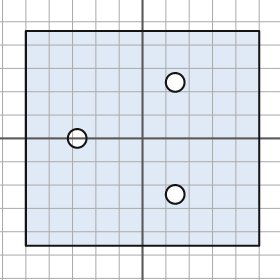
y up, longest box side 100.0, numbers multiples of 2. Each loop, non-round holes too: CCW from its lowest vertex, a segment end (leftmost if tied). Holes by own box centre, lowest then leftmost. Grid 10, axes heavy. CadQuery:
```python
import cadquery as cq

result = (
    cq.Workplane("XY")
    .moveTo(-50.0, -46.0)
    .lineTo(50.0, -46.0)
    .lineTo(50.0, 46.0)
    .lineTo(-50.0, 46.0)
    .close()
    .moveTo(14.0, -24.0)
    .circle(4.0)
    .moveTo(-28.0, 0.0)
    .circle(4.0)
    .moveTo(14.0, 24.0)
    .circle(4.0)
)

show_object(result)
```